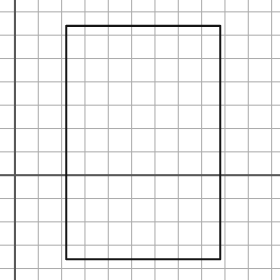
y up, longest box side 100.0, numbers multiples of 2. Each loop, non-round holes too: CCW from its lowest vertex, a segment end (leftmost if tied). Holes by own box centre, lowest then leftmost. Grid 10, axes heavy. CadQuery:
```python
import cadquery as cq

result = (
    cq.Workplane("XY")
    .moveTo(22.0, -36.0)
    .lineTo(88.0, -36.0)
    .lineTo(88.0, 64.0)
    .lineTo(22.0, 64.0)
    .close()
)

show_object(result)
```